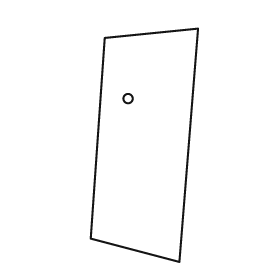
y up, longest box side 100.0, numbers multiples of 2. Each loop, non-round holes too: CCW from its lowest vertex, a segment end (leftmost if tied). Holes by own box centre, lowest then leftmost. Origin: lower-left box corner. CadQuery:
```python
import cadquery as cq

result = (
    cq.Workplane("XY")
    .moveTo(38.0, 0.0)
    .lineTo(46.0, 100.0)
    .lineTo(6.0, 96.0)
    .lineTo(0.0, 10.0)
    .close()
    .moveTo(16.0, 70.0)
    .circle(2.0)
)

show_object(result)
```